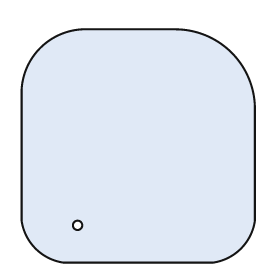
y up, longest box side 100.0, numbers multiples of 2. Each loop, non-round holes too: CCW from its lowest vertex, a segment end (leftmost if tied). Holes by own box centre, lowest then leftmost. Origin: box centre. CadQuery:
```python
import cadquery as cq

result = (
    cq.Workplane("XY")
    .moveTo(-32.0, -50.0)
    .lineTo(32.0, -50.0)
    .threePointArc((44.0, -44.0), (50.0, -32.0))
    .lineTo(50.0, 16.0)
    .threePointArc((40.0, 40.0), (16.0, 50.0))
    .lineTo(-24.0, 50.0)
    .threePointArc((-42.0, 42.0), (-50.0, 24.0))
    .lineTo(-50.0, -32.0)
    .threePointArc((-44.0, -44.0), (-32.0, -50.0))
    .close()
    .moveTo(-26.0, -34.0)
    .circle(2.0)
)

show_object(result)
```